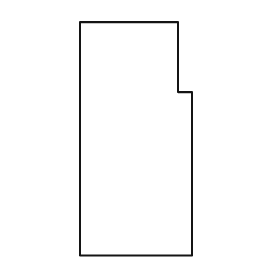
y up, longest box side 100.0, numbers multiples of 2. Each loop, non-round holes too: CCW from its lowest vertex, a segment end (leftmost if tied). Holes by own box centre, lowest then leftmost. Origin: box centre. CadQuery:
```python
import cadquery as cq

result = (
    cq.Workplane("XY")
    .moveTo(-24.0, -50.0)
    .lineTo(24.0, -50.0)
    .lineTo(24.0, 20.0)
    .lineTo(18.0, 20.0)
    .lineTo(18.0, 50.0)
    .lineTo(-24.0, 50.0)
    .close()
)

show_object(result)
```